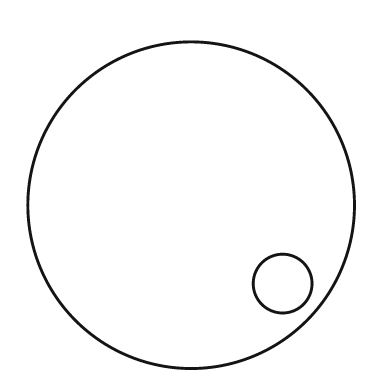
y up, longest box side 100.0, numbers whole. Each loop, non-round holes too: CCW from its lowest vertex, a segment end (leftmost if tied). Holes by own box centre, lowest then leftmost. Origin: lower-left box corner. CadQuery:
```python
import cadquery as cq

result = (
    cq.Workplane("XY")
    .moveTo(50.0, 50.0)
    .circle(50.0)
    .moveTo(78.0, 26.0)
    .circle(9.0)
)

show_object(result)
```